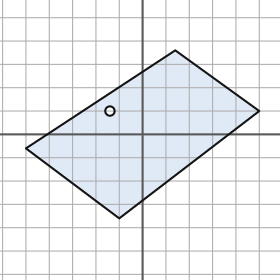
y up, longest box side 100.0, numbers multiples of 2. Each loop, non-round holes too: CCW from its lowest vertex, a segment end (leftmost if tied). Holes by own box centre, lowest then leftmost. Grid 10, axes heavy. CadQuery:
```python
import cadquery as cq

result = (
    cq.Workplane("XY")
    .moveTo(-10.0, -36.0)
    .lineTo(50.0, 10.0)
    .lineTo(14.0, 36.0)
    .lineTo(-50.0, -6.0)
    .close()
    .moveTo(-14.0, 10.0)
    .circle(2.0)
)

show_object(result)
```